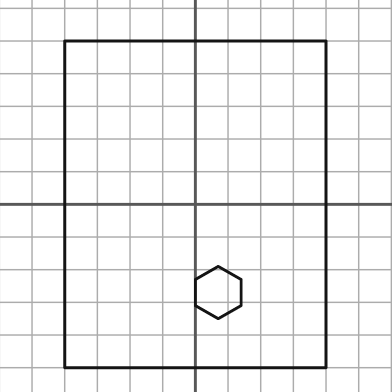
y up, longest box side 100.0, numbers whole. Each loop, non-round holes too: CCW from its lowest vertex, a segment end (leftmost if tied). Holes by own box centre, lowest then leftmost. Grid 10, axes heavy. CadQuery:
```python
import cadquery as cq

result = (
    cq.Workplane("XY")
    .moveTo(-40.0, -50.0)
    .lineTo(40.0, -50.0)
    .lineTo(40.0, 50.0)
    .lineTo(-40.0, 50.0)
    .close()
    .moveTo(7.0, -35.0)
    .lineTo(14.0, -31.0)
    .lineTo(14.0, -23.0)
    .lineTo(7.0, -19.0)
    .lineTo(0.0, -23.0)
    .lineTo(0.0, -31.0)
    .close()
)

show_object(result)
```